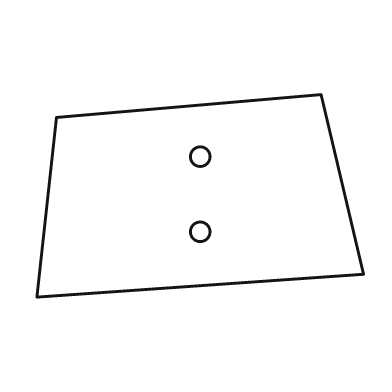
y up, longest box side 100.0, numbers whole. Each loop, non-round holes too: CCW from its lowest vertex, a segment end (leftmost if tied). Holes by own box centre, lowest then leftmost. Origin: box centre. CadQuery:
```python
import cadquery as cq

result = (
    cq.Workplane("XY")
    .moveTo(-50.0, -31.0)
    .lineTo(50.0, -24.0)
    .lineTo(37.0, 31.0)
    .lineTo(-44.0, 24.0)
    .close()
    .moveTo(0.0, -11.0)
    .circle(3.0)
    .moveTo(0.0, 12.0)
    .circle(3.0)
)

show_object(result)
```